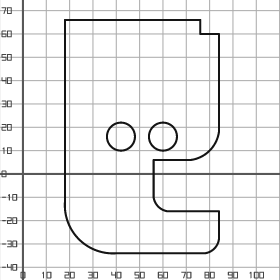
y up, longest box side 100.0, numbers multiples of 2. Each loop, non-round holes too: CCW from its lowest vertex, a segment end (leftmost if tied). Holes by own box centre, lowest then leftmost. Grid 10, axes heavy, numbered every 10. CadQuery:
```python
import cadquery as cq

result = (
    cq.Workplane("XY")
    .moveTo(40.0, -34.0)
    .lineTo(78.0, -34.0)
    .threePointArc((82.0, -32.0), (84.0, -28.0))
    .lineTo(84.0, -16.0)
    .lineTo(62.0, -16.0)
    .threePointArc((58.0, -14.0), (56.0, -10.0))
    .lineTo(56.0, 6.0)
    .lineTo(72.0, 6.0)
    .threePointArc((80.0, 10.0), (84.0, 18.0))
    .lineTo(84.0, 60.0)
    .lineTo(76.0, 60.0)
    .lineTo(76.0, 66.0)
    .lineTo(18.0, 66.0)
    .lineTo(18.0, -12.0)
    .threePointArc((24.0, -28.0), (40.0, -34.0))
    .close()
    .moveTo(42.0, 16.0)
    .circle(6.0)
    .moveTo(60.0, 16.0)
    .circle(6.0)
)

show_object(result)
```